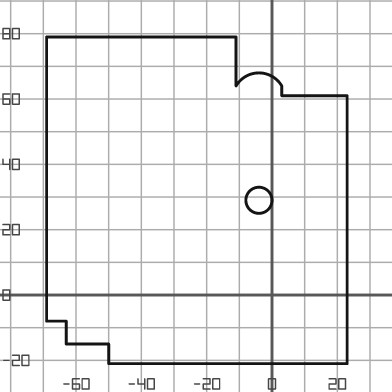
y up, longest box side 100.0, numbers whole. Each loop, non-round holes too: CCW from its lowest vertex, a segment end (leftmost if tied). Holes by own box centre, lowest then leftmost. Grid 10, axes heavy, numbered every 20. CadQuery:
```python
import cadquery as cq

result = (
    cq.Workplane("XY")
    .moveTo(-50.0, -21.0)
    .lineTo(23.0, -21.0)
    .lineTo(23.0, 61.0)
    .lineTo(3.0, 61.0)
    .lineTo(3.0, 64.0)
    .threePointArc((-4.0, 68.0), (-11.0, 64.0))
    .lineTo(-11.0, 79.0)
    .lineTo(-69.0, 79.0)
    .lineTo(-69.0, -8.0)
    .lineTo(-63.0, -8.0)
    .lineTo(-63.0, -15.0)
    .lineTo(-50.0, -15.0)
    .close()
    .moveTo(-4.0, 29.0)
    .circle(4.0)
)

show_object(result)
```